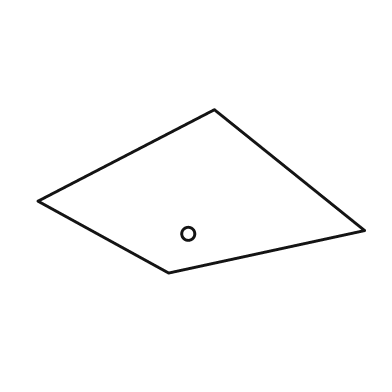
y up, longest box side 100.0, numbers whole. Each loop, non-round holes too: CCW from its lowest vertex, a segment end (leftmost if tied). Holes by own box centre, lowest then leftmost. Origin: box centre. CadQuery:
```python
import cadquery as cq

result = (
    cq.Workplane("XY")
    .moveTo(-10.0, -25.0)
    .lineTo(50.0, -12.0)
    .lineTo(4.0, 25.0)
    .lineTo(-50.0, -3.0)
    .close()
    .moveTo(-4.0, -13.0)
    .circle(2.0)
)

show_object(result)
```